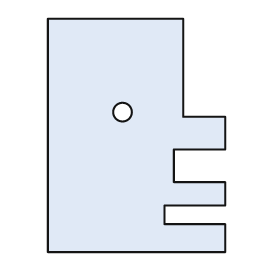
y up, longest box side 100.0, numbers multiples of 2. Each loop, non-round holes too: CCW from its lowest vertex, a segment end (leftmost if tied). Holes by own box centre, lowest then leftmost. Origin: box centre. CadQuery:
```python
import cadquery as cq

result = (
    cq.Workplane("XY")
    .moveTo(-38.0, -50.0)
    .lineTo(38.0, -50.0)
    .lineTo(38.0, -38.0)
    .lineTo(12.0, -38.0)
    .lineTo(12.0, -30.0)
    .lineTo(38.0, -30.0)
    .lineTo(38.0, -20.0)
    .lineTo(16.0, -20.0)
    .lineTo(16.0, -6.0)
    .lineTo(38.0, -6.0)
    .lineTo(38.0, 8.0)
    .lineTo(20.0, 8.0)
    .lineTo(20.0, 50.0)
    .lineTo(-38.0, 50.0)
    .close()
    .moveTo(-6.0, 10.0)
    .circle(4.0)
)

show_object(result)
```